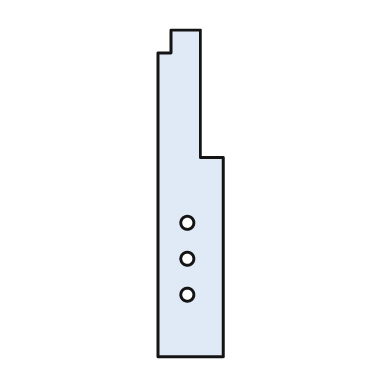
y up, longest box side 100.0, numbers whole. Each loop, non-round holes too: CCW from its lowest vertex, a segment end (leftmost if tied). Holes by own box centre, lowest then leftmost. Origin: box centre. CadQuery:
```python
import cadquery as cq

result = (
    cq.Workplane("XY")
    .moveTo(-10.0, -50.0)
    .lineTo(10.0, -50.0)
    .lineTo(10.0, 11.0)
    .lineTo(3.0, 11.0)
    .lineTo(3.0, 50.0)
    .lineTo(-6.0, 50.0)
    .lineTo(-6.0, 43.0)
    .lineTo(-10.0, 43.0)
    .close()
    .moveTo(-1.0, -31.0)
    .circle(2.0)
    .moveTo(-1.0, -20.0)
    .circle(2.0)
    .moveTo(-1.0, -9.0)
    .circle(2.0)
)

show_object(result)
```